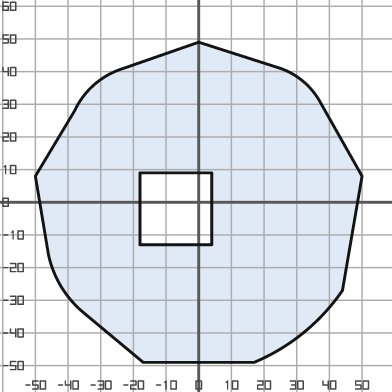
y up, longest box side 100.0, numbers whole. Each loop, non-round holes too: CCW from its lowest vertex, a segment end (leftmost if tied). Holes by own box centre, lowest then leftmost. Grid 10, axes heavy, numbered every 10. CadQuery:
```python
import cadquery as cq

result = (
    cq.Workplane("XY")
    .moveTo(-17.0, -49.0)
    .lineTo(17.0, -49.0)
    .threePointArc((32.0, -40.0), (44.0, -27.0))
    .lineTo(50.0, 8.0)
    .lineTo(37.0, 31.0)
    .threePointArc((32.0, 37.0), (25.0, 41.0))
    .lineTo(0.0, 49.0)
    .lineTo(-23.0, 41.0)
    .threePointArc((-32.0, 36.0), (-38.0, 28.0))
    .lineTo(-50.0, 8.0)
    .lineTo(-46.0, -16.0)
    .threePointArc((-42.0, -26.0), (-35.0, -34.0))
    .close()
    .moveTo(-18.0, -13.0)
    .lineTo(4.0, -13.0)
    .lineTo(4.0, 9.0)
    .lineTo(-18.0, 9.0)
    .close()
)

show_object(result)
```